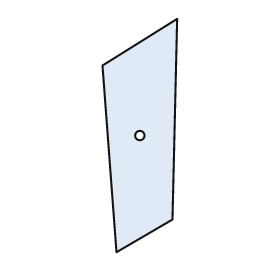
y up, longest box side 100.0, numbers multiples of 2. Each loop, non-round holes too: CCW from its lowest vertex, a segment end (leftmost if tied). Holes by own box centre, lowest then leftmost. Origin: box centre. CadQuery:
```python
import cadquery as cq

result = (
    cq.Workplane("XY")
    .moveTo(-10.0, -50.0)
    .lineTo(14.0, -36.0)
    .lineTo(16.0, 50.0)
    .lineTo(-16.0, 30.0)
    .close()
    .moveTo(0.0, 0.0)
    .circle(2.0)
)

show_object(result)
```